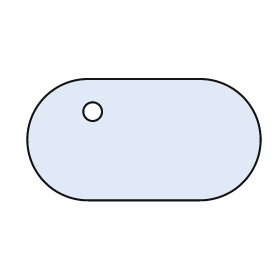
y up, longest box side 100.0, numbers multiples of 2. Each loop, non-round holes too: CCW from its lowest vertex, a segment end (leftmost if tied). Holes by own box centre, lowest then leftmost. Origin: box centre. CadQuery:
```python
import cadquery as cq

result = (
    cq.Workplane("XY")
    .moveTo(-24.0, -26.0)
    .lineTo(24.0, -26.0)
    .threePointArc((50.0, 0.0), (24.0, 26.0))
    .lineTo(-24.0, 26.0)
    .threePointArc((-50.0, 0.0), (-24.0, -26.0))
    .close()
    .moveTo(-22.0, 12.0)
    .circle(4.0)
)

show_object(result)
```